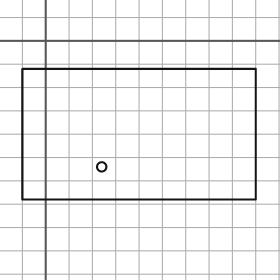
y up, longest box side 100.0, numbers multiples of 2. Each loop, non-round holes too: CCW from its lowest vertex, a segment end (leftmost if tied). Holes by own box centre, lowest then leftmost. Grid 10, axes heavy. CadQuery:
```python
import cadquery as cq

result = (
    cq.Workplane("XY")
    .moveTo(-10.0, -68.0)
    .lineTo(90.0, -68.0)
    .lineTo(90.0, -12.0)
    .lineTo(-10.0, -12.0)
    .close()
    .moveTo(24.0, -54.0)
    .circle(2.0)
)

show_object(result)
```